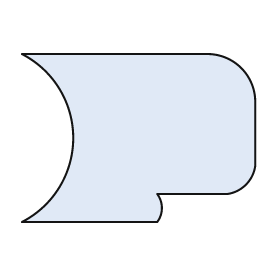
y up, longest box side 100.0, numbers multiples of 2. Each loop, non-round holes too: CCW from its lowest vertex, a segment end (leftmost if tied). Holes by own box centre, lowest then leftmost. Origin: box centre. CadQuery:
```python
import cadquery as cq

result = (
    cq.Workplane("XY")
    .moveTo(-50.0, -36.0)
    .lineTo(8.0, -36.0)
    .threePointArc((10.0, -30.0), (8.0, -24.0))
    .lineTo(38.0, -24.0)
    .threePointArc((46.0, -20.0), (50.0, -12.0))
    .lineTo(50.0, 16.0)
    .threePointArc((44.0, 30.0), (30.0, 36.0))
    .lineTo(-50.0, 36.0)
    .threePointArc((-28.0, 0.0), (-50.0, -36.0))
    .close()
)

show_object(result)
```